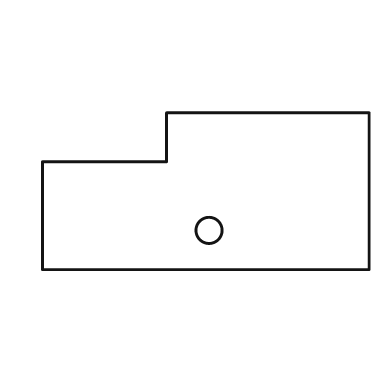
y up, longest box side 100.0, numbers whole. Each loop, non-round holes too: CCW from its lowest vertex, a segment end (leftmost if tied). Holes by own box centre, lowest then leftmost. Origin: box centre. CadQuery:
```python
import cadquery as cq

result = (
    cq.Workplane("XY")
    .moveTo(-50.0, -24.0)
    .lineTo(50.0, -24.0)
    .lineTo(50.0, 24.0)
    .lineTo(-12.0, 24.0)
    .lineTo(-12.0, 9.0)
    .lineTo(-50.0, 9.0)
    .close()
    .moveTo(1.0, -12.0)
    .circle(4.0)
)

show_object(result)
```